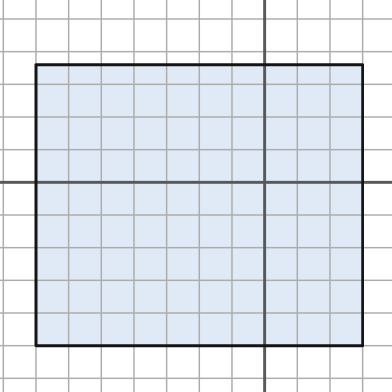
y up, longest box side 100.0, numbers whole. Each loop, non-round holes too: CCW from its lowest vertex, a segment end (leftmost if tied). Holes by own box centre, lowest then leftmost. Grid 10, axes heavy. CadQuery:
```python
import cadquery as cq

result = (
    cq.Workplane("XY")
    .moveTo(-70.0, -50.0)
    .lineTo(30.0, -50.0)
    .lineTo(30.0, 36.0)
    .lineTo(-70.0, 36.0)
    .close()
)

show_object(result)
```